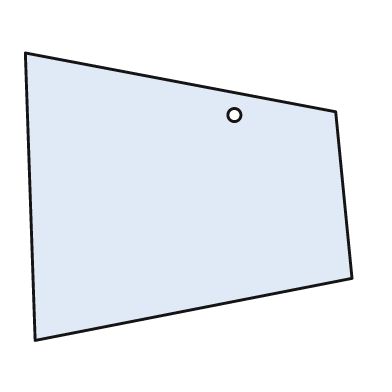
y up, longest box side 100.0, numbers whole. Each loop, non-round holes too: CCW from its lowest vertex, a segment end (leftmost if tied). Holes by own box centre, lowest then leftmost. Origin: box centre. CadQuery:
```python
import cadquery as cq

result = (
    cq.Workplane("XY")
    .moveTo(-47.0, -44.0)
    .lineTo(50.0, -25.0)
    .lineTo(45.0, 26.0)
    .lineTo(-50.0, 44.0)
    .close()
    .moveTo(14.0, 25.0)
    .circle(2.0)
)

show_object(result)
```